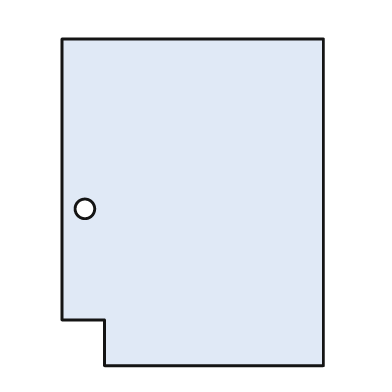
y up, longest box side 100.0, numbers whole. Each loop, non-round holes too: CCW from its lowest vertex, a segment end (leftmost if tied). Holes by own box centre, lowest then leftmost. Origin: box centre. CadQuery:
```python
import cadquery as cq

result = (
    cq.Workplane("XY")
    .moveTo(-27.0, -50.0)
    .lineTo(40.0, -50.0)
    .lineTo(40.0, 50.0)
    .lineTo(-40.0, 50.0)
    .lineTo(-40.0, -36.0)
    .lineTo(-27.0, -36.0)
    .close()
    .moveTo(-33.0, -2.0)
    .circle(3.0)
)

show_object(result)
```